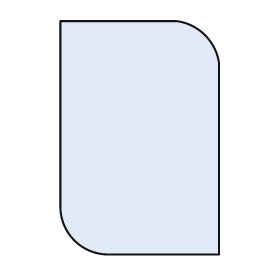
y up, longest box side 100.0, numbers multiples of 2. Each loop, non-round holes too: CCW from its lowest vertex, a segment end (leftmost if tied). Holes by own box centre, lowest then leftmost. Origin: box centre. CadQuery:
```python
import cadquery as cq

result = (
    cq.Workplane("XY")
    .moveTo(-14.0, -50.0)
    .lineTo(34.0, -50.0)
    .lineTo(34.0, 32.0)
    .threePointArc((28.0, 44.0), (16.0, 50.0))
    .lineTo(-34.0, 50.0)
    .lineTo(-34.0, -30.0)
    .threePointArc((-28.0, -44.0), (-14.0, -50.0))
    .close()
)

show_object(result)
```